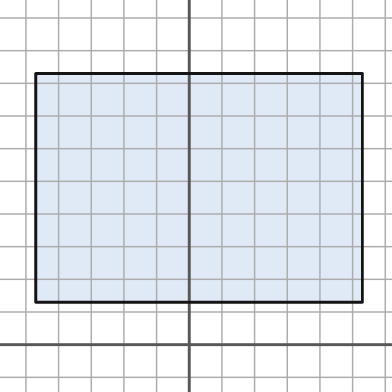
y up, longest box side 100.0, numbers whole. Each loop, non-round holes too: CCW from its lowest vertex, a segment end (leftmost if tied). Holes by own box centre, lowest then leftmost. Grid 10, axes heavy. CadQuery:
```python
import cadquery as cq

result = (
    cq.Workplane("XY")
    .moveTo(-47.0, 13.0)
    .lineTo(53.0, 13.0)
    .lineTo(53.0, 83.0)
    .lineTo(-47.0, 83.0)
    .close()
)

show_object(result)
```